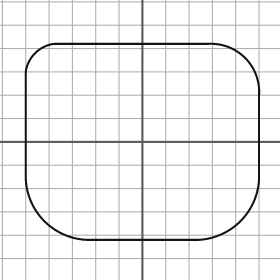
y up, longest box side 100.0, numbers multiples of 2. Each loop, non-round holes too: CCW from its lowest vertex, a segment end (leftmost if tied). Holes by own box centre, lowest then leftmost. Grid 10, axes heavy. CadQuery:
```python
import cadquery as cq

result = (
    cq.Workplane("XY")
    .moveTo(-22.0, -42.0)
    .lineTo(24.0, -42.0)
    .threePointArc((42.0, -34.0), (50.0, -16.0))
    .lineTo(50.0, 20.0)
    .threePointArc((44.0, 36.0), (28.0, 42.0))
    .lineTo(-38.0, 42.0)
    .threePointArc((-46.0, 38.0), (-50.0, 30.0))
    .lineTo(-50.0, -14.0)
    .threePointArc((-42.0, -34.0), (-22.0, -42.0))
    .close()
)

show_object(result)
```